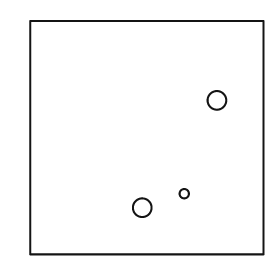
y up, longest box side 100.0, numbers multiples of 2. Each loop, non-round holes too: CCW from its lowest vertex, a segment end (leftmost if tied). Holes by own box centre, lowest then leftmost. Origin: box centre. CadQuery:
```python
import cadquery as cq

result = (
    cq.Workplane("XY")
    .moveTo(-50.0, -50.0)
    .lineTo(50.0, -50.0)
    .lineTo(50.0, 50.0)
    .lineTo(-50.0, 50.0)
    .close()
    .moveTo(-2.0, -30.0)
    .circle(4.0)
    .moveTo(16.0, -24.0)
    .circle(2.0)
    .moveTo(30.0, 16.0)
    .circle(4.0)
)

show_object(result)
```